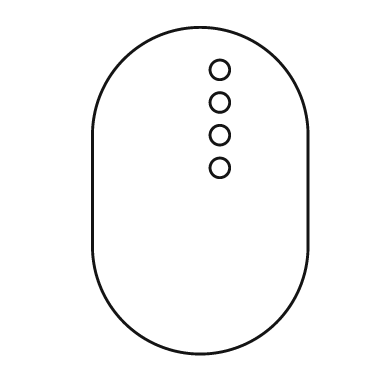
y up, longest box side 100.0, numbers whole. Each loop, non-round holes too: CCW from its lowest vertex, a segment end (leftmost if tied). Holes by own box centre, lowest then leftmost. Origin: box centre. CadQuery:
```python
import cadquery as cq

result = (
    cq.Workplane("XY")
    .moveTo(-33.0, -17.0)
    .threePointArc((0.0, -50.0), (33.0, -17.0))
    .lineTo(33.0, 17.0)
    .threePointArc((0.0, 50.0), (-33.0, 17.0))
    .close()
    .moveTo(6.0, 7.0)
    .circle(3.0)
    .moveTo(6.0, 17.0)
    .circle(3.0)
    .moveTo(6.0, 27.0)
    .circle(3.0)
    .moveTo(6.0, 37.0)
    .circle(3.0)
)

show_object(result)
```